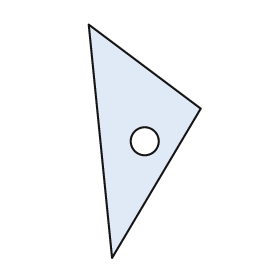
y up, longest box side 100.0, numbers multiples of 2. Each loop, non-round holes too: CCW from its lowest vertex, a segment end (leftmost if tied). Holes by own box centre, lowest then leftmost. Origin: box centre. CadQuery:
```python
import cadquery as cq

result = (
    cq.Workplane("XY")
    .moveTo(-14.0, -50.0)
    .lineTo(24.0, 14.0)
    .lineTo(-24.0, 50.0)
    .close()
    .moveTo(0.0, 0.0)
    .circle(6.0)
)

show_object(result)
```